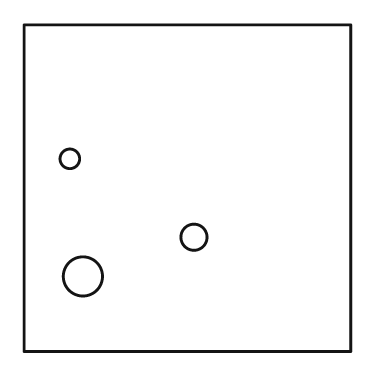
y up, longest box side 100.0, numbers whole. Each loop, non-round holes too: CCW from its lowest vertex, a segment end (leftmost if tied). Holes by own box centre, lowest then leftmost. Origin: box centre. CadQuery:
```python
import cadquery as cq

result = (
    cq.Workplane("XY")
    .moveTo(-50.0, -50.0)
    .lineTo(50.0, -50.0)
    .lineTo(50.0, 50.0)
    .lineTo(-50.0, 50.0)
    .close()
    .moveTo(-32.0, -27.0)
    .circle(6.0)
    .moveTo(2.0, -15.0)
    .circle(4.0)
    .moveTo(-36.0, 9.0)
    .circle(3.0)
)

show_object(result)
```